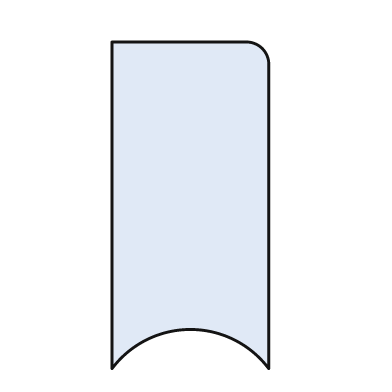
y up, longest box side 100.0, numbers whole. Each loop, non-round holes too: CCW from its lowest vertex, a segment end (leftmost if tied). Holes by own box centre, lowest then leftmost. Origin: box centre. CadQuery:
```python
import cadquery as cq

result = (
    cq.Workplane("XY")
    .moveTo(-24.0, -50.0)
    .threePointArc((0.0, -38.0), (24.0, -50.0))
    .lineTo(24.0, 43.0)
    .threePointArc((22.0, 48.0), (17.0, 50.0))
    .lineTo(-24.0, 50.0)
    .close()
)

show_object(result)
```